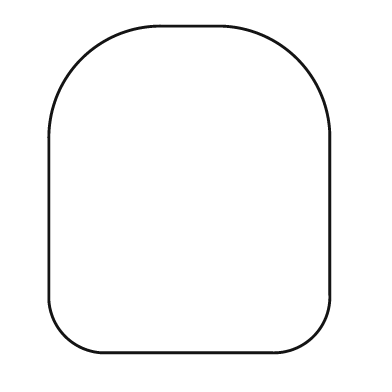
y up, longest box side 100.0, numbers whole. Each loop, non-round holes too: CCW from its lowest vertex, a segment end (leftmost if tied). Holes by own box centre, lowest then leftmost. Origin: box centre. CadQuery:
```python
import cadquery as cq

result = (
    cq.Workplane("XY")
    .moveTo(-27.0, -50.0)
    .lineTo(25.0, -50.0)
    .threePointArc((38.0, -45.0), (43.0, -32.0))
    .lineTo(43.0, 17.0)
    .threePointArc((33.0, 40.0), (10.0, 50.0))
    .lineTo(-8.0, 50.0)
    .threePointArc((-33.0, 40.0), (-43.0, 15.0))
    .lineTo(-43.0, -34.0)
    .threePointArc((-38.0, -45.0), (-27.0, -50.0))
    .close()
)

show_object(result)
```